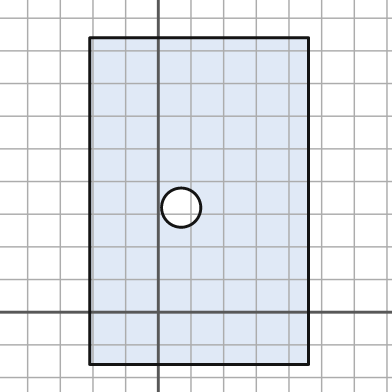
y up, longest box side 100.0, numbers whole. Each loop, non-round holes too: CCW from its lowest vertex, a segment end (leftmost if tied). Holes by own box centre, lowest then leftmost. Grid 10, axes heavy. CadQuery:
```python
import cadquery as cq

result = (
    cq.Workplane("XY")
    .moveTo(-21.0, -16.0)
    .lineTo(46.0, -16.0)
    .lineTo(46.0, 84.0)
    .lineTo(-21.0, 84.0)
    .close()
    .moveTo(7.0, 32.0)
    .circle(6.0)
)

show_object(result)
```